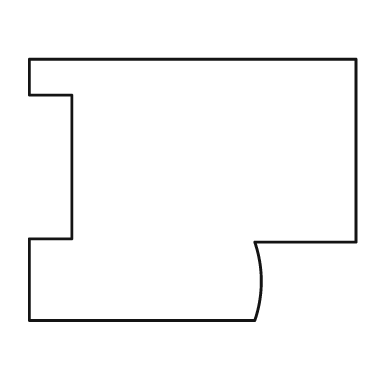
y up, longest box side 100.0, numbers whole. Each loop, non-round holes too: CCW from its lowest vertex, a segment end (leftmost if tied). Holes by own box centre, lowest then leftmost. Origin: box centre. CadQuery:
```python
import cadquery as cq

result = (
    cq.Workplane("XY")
    .moveTo(-50.0, -40.0)
    .lineTo(19.0, -40.0)
    .threePointArc((21.0, -28.0), (19.0, -16.0))
    .lineTo(50.0, -16.0)
    .lineTo(50.0, 40.0)
    .lineTo(-50.0, 40.0)
    .lineTo(-50.0, 29.0)
    .lineTo(-37.0, 29.0)
    .lineTo(-37.0, -15.0)
    .lineTo(-50.0, -15.0)
    .close()
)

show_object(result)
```